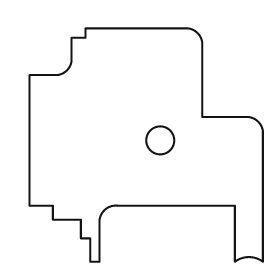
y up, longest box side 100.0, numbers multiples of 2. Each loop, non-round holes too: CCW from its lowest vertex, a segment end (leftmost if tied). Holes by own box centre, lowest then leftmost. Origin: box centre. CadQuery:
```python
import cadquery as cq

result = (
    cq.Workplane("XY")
    .moveTo(-24.0, -50.0)
    .lineTo(-20.0, -50.0)
    .lineTo(-20.0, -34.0)
    .threePointArc((-18.0, -28.0), (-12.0, -26.0))
    .lineTo(38.0, -26.0)
    .lineTo(38.0, -50.0)
    .threePointArc((44.0, -48.0), (50.0, -50.0))
    .lineTo(50.0, 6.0)
    .threePointArc((48.0, 10.0), (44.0, 12.0))
    .lineTo(24.0, 12.0)
    .lineTo(24.0, 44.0)
    .threePointArc((22.0, 48.0), (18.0, 50.0))
    .lineTo(-26.0, 50.0)
    .lineTo(-26.0, 46.0)
    .lineTo(-32.0, 46.0)
    .lineTo(-32.0, 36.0)
    .threePointArc((-34.0, 32.0), (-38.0, 30.0))
    .lineTo(-50.0, 30.0)
    .lineTo(-50.0, -26.0)
    .lineTo(-40.0, -26.0)
    .lineTo(-40.0, -32.0)
    .lineTo(-28.0, -32.0)
    .lineTo(-28.0, -40.0)
    .lineTo(-24.0, -40.0)
    .close()
    .moveTo(6.0, 2.0)
    .circle(6.0)
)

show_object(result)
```